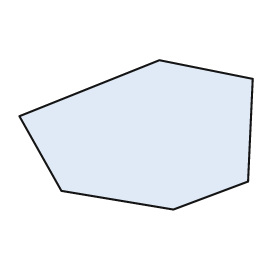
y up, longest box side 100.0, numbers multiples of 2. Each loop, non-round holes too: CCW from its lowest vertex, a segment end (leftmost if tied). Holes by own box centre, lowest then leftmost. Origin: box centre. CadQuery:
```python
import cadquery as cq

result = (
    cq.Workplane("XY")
    .moveTo(16.0, -32.0)
    .lineTo(48.0, -20.0)
    .lineTo(50.0, 24.0)
    .lineTo(10.0, 32.0)
    .lineTo(-50.0, 8.0)
    .lineTo(-32.0, -24.0)
    .close()
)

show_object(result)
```